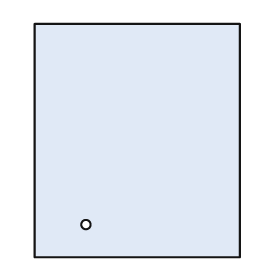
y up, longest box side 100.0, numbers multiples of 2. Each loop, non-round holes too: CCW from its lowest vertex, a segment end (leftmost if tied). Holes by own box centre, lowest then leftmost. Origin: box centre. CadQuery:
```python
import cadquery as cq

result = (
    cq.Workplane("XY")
    .moveTo(-44.0, -50.0)
    .lineTo(44.0, -50.0)
    .lineTo(44.0, 50.0)
    .lineTo(-44.0, 50.0)
    .close()
    .moveTo(-22.0, -36.0)
    .circle(2.0)
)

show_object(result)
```